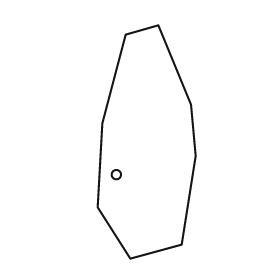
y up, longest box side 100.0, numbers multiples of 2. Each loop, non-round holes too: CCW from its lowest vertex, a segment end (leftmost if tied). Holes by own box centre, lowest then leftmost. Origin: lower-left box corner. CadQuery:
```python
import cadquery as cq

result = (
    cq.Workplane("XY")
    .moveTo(14.0, 0.0)
    .lineTo(36.0, 6.0)
    .lineTo(42.0, 44.0)
    .lineTo(40.0, 66.0)
    .lineTo(26.0, 100.0)
    .lineTo(12.0, 96.0)
    .lineTo(2.0, 58.0)
    .lineTo(0.0, 22.0)
    .close()
    .moveTo(8.0, 36.0)
    .circle(2.0)
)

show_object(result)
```